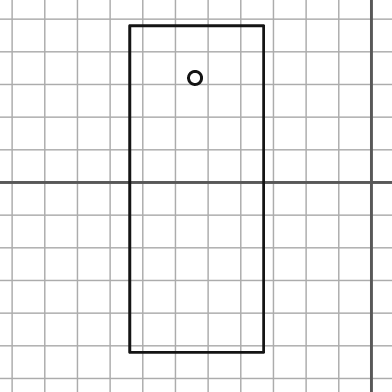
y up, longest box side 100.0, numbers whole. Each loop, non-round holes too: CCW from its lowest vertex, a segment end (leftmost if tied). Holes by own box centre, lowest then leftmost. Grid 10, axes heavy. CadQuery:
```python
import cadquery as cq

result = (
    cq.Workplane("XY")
    .moveTo(-74.0, -52.0)
    .lineTo(-33.0, -52.0)
    .lineTo(-33.0, 48.0)
    .lineTo(-74.0, 48.0)
    .close()
    .moveTo(-54.0, 32.0)
    .circle(2.0)
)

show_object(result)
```